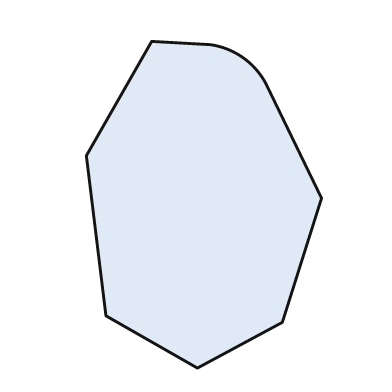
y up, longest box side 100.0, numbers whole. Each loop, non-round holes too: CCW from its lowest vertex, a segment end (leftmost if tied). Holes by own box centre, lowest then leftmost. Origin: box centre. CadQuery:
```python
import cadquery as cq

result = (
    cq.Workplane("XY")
    .moveTo(-2.0, -50.0)
    .lineTo(24.0, -36.0)
    .lineTo(36.0, 2.0)
    .lineTo(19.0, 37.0)
    .threePointArc((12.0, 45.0), (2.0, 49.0))
    .lineTo(-16.0, 50.0)
    .lineTo(-36.0, 15.0)
    .lineTo(-30.0, -34.0)
    .close()
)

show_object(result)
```